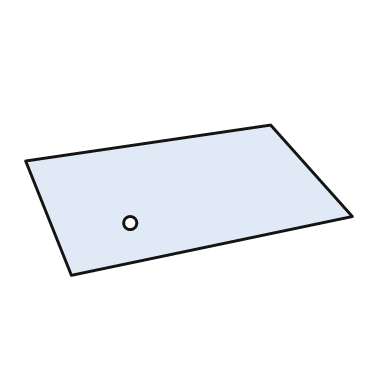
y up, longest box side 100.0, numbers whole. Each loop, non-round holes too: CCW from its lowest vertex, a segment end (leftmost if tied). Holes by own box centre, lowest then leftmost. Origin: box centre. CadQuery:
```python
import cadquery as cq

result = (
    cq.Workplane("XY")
    .moveTo(-36.0, -23.0)
    .lineTo(50.0, -5.0)
    .lineTo(25.0, 23.0)
    .lineTo(-50.0, 12.0)
    .close()
    .moveTo(-18.0, -7.0)
    .circle(2.0)
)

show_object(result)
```